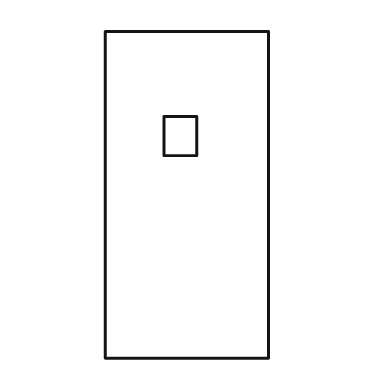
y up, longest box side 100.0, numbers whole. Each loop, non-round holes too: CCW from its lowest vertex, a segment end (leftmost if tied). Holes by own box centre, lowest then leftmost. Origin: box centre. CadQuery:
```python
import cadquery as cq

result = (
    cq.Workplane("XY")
    .moveTo(-25.0, -50.0)
    .lineTo(25.0, -50.0)
    .lineTo(25.0, 50.0)
    .lineTo(-25.0, 50.0)
    .close()
    .moveTo(-7.0, 12.0)
    .lineTo(3.0, 12.0)
    .lineTo(3.0, 24.0)
    .lineTo(-7.0, 24.0)
    .close()
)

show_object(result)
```